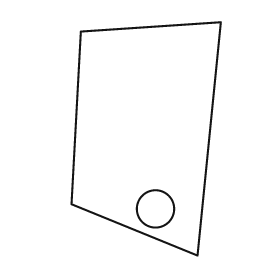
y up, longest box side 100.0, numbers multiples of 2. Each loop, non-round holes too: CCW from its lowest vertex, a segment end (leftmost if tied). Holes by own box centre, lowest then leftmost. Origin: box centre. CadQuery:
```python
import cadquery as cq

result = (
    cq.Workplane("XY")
    .moveTo(22.0, -50.0)
    .lineTo(32.0, 50.0)
    .lineTo(-28.0, 46.0)
    .lineTo(-32.0, -28.0)
    .close()
    .moveTo(4.0, -30.0)
    .circle(8.0)
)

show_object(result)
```